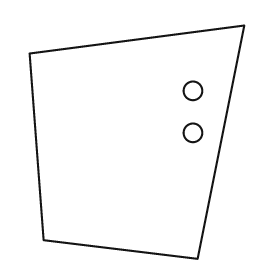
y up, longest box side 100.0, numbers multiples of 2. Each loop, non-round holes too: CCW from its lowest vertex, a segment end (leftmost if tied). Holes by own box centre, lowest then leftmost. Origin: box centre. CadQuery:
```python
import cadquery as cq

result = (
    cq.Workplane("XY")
    .moveTo(26.0, -50.0)
    .lineTo(46.0, 50.0)
    .lineTo(-46.0, 38.0)
    .lineTo(-40.0, -42.0)
    .close()
    .moveTo(24.0, 4.0)
    .circle(4.0)
    .moveTo(24.0, 22.0)
    .circle(4.0)
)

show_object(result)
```